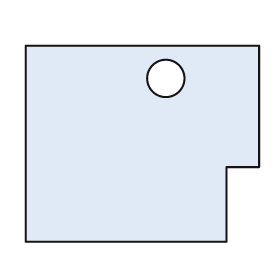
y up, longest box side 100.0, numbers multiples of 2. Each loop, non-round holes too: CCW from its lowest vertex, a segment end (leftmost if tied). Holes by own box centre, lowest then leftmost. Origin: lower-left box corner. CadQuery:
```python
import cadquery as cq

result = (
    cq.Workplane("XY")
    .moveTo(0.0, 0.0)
    .lineTo(86.0, 0.0)
    .lineTo(86.0, 32.0)
    .lineTo(100.0, 32.0)
    .lineTo(100.0, 84.0)
    .lineTo(0.0, 84.0)
    .close()
    .moveTo(60.0, 70.0)
    .circle(8.0)
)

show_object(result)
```